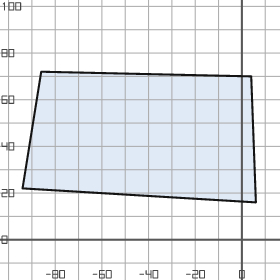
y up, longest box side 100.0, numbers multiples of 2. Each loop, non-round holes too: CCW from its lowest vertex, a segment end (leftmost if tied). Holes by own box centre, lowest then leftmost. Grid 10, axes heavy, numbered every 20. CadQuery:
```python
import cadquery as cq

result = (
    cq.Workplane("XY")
    .moveTo(6.0, 16.0)
    .lineTo(4.0, 70.0)
    .lineTo(-86.0, 72.0)
    .lineTo(-94.0, 22.0)
    .close()
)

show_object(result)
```